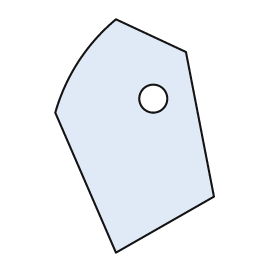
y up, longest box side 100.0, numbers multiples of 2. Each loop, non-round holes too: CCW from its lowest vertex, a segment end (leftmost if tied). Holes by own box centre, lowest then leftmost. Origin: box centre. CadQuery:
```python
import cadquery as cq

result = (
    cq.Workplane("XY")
    .moveTo(-8.0, -50.0)
    .lineTo(34.0, -26.0)
    .lineTo(22.0, 36.0)
    .lineTo(-8.0, 50.0)
    .threePointArc((-24.0, 32.0), (-34.0, 10.0))
    .close()
    .moveTo(8.0, 16.0)
    .circle(6.0)
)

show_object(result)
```